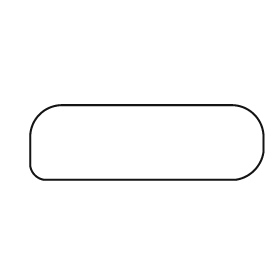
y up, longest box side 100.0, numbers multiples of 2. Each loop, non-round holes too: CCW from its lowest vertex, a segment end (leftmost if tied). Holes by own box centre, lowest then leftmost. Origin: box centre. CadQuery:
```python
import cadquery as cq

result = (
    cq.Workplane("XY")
    .moveTo(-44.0, -16.0)
    .lineTo(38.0, -16.0)
    .threePointArc((46.0, -12.0), (50.0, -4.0))
    .lineTo(50.0, 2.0)
    .threePointArc((46.0, 12.0), (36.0, 16.0))
    .lineTo(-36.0, 16.0)
    .threePointArc((-46.0, 12.0), (-50.0, 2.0))
    .lineTo(-50.0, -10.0)
    .threePointArc((-48.0, -14.0), (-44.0, -16.0))
    .close()
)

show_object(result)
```